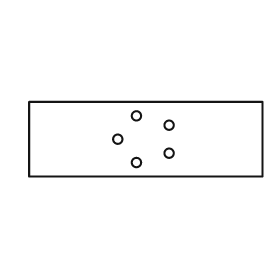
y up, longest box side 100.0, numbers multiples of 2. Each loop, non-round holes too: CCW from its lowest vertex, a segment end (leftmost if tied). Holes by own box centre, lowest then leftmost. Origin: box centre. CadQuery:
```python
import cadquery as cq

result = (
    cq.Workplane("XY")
    .moveTo(-50.0, -16.0)
    .lineTo(50.0, -16.0)
    .lineTo(50.0, 16.0)
    .lineTo(-50.0, 16.0)
    .close()
    .moveTo(-4.0, -10.0)
    .circle(2.0)
    .moveTo(10.0, -6.0)
    .circle(2.0)
    .moveTo(-12.0, 0.0)
    .circle(2.0)
    .moveTo(10.0, 6.0)
    .circle(2.0)
    .moveTo(-4.0, 10.0)
    .circle(2.0)
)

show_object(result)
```